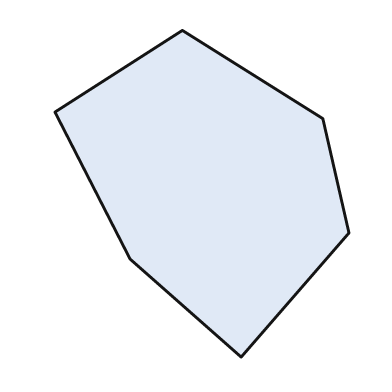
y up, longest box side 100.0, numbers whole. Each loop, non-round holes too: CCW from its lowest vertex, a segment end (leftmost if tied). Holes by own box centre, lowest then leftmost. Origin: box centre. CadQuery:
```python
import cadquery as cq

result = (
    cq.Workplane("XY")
    .moveTo(12.0, -50.0)
    .lineTo(45.0, -12.0)
    .lineTo(37.0, 23.0)
    .lineTo(-6.0, 50.0)
    .lineTo(-45.0, 25.0)
    .lineTo(-22.0, -20.0)
    .close()
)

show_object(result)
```